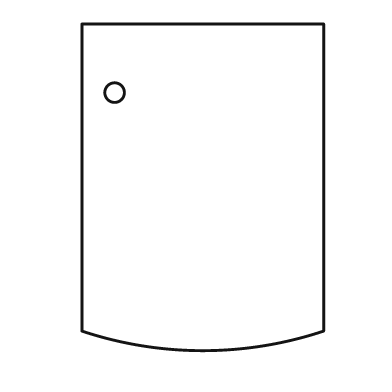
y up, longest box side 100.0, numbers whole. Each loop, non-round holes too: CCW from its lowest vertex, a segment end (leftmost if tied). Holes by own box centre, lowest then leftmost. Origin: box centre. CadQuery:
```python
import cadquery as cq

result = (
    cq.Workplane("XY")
    .moveTo(-37.0, -44.0)
    .threePointArc((0.0, -50.0), (37.0, -44.0))
    .lineTo(37.0, 50.0)
    .lineTo(-37.0, 50.0)
    .close()
    .moveTo(-27.0, 29.0)
    .circle(3.0)
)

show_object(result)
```